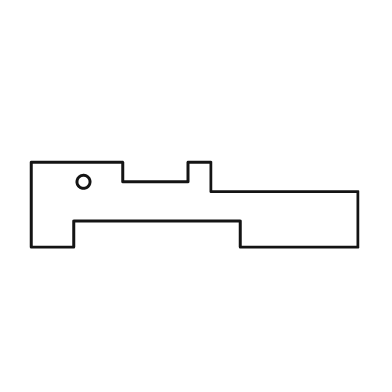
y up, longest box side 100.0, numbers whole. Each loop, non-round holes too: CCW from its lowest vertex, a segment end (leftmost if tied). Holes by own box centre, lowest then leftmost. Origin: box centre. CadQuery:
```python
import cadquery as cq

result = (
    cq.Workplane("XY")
    .moveTo(-50.0, -13.0)
    .lineTo(-37.0, -13.0)
    .lineTo(-37.0, -5.0)
    .lineTo(14.0, -5.0)
    .lineTo(14.0, -13.0)
    .lineTo(50.0, -13.0)
    .lineTo(50.0, 4.0)
    .lineTo(5.0, 4.0)
    .lineTo(5.0, 13.0)
    .lineTo(-2.0, 13.0)
    .lineTo(-2.0, 7.0)
    .lineTo(-22.0, 7.0)
    .lineTo(-22.0, 13.0)
    .lineTo(-50.0, 13.0)
    .close()
    .moveTo(-34.0, 7.0)
    .circle(2.0)
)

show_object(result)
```